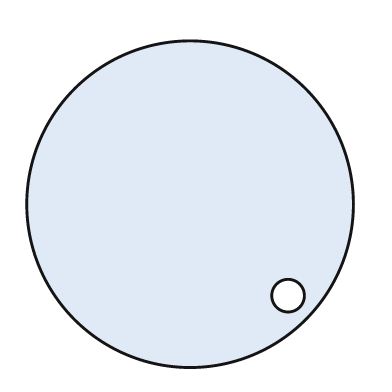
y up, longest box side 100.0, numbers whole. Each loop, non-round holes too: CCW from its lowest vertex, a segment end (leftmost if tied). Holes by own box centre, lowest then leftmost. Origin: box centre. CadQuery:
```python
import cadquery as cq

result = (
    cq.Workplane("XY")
    .moveTo(0.0, 0.0)
    .circle(50.0)
    .moveTo(30.0, -28.0)
    .circle(5.0)
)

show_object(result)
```